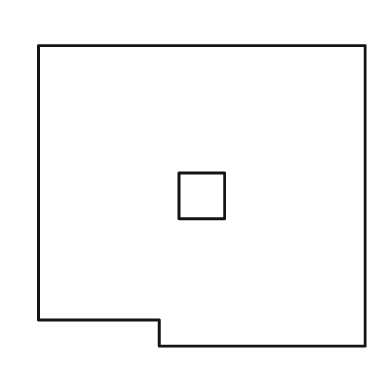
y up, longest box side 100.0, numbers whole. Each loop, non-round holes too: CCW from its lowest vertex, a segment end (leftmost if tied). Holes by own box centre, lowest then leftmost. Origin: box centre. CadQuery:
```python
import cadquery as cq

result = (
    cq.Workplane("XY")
    .moveTo(-13.0, -46.0)
    .lineTo(50.0, -46.0)
    .lineTo(50.0, 46.0)
    .lineTo(-50.0, 46.0)
    .lineTo(-50.0, -38.0)
    .lineTo(-13.0, -38.0)
    .close()
    .moveTo(-7.0, -7.0)
    .lineTo(7.0, -7.0)
    .lineTo(7.0, 7.0)
    .lineTo(-7.0, 7.0)
    .close()
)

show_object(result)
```